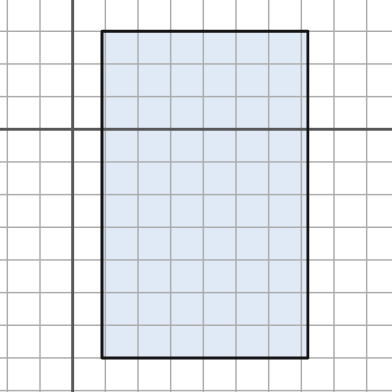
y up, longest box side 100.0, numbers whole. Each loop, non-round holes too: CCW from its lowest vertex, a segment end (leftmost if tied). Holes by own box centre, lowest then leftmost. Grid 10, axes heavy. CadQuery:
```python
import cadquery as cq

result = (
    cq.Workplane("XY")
    .moveTo(9.0, -70.0)
    .lineTo(72.0, -70.0)
    .lineTo(72.0, 30.0)
    .lineTo(9.0, 30.0)
    .close()
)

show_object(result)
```